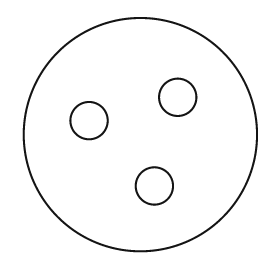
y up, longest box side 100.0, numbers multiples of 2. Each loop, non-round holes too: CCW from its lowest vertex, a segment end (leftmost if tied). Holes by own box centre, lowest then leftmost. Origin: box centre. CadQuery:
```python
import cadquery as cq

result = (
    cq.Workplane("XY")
    .moveTo(0.0, 0.0)
    .circle(50.0)
    .moveTo(6.0, -22.0)
    .circle(8.0)
    .moveTo(-22.0, 6.0)
    .circle(8.0)
    .moveTo(16.0, 16.0)
    .circle(8.0)
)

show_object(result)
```